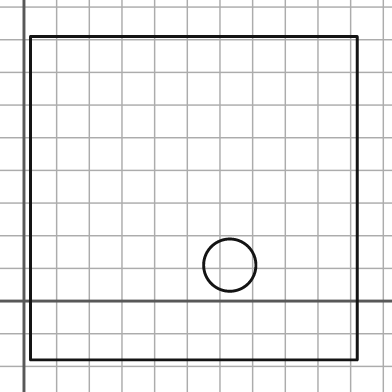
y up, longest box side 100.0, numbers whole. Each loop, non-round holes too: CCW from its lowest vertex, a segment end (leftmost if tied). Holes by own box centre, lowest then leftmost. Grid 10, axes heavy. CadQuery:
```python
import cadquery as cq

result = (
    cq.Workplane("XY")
    .moveTo(2.0, -18.0)
    .lineTo(102.0, -18.0)
    .lineTo(102.0, 81.0)
    .lineTo(2.0, 81.0)
    .close()
    .moveTo(63.0, 11.0)
    .circle(8.0)
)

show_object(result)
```